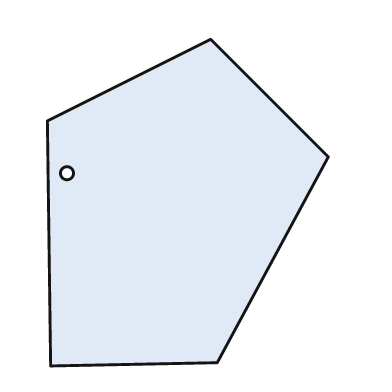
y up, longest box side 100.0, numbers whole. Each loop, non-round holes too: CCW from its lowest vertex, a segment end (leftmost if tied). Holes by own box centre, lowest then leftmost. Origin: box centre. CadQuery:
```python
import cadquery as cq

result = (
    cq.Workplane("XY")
    .moveTo(-42.0, -50.0)
    .lineTo(9.0, -49.0)
    .lineTo(43.0, 14.0)
    .lineTo(7.0, 50.0)
    .lineTo(-43.0, 25.0)
    .close()
    .moveTo(-37.0, 9.0)
    .circle(2.0)
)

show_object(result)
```